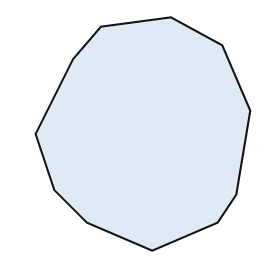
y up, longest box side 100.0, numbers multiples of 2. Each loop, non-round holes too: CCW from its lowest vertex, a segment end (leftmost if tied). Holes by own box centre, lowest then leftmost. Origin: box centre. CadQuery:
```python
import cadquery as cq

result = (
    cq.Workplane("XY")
    .moveTo(4.0, -50.0)
    .lineTo(32.0, -38.0)
    .lineTo(40.0, -26.0)
    .lineTo(46.0, 10.0)
    .lineTo(34.0, 38.0)
    .lineTo(12.0, 50.0)
    .lineTo(-18.0, 46.0)
    .lineTo(-30.0, 32.0)
    .lineTo(-46.0, 0.0)
    .lineTo(-38.0, -24.0)
    .lineTo(-24.0, -38.0)
    .close()
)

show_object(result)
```